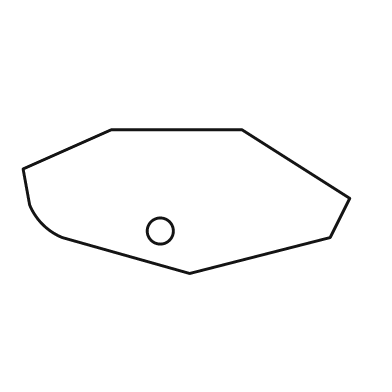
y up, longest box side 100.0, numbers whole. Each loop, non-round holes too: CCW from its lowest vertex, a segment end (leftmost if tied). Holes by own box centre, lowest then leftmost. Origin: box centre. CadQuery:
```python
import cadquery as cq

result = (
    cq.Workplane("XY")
    .moveTo(1.0, -22.0)
    .lineTo(44.0, -11.0)
    .lineTo(50.0, 1.0)
    .lineTo(17.0, 22.0)
    .lineTo(-23.0, 22.0)
    .lineTo(-50.0, 10.0)
    .lineTo(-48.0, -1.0)
    .threePointArc((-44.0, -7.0), (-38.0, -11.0))
    .close()
    .moveTo(-8.0, -9.0)
    .circle(4.0)
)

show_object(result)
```